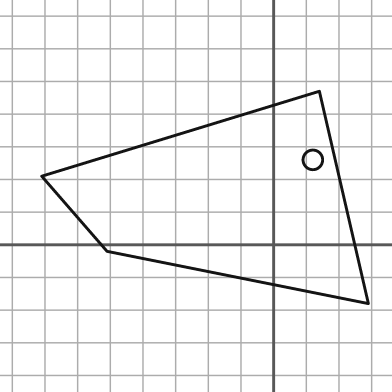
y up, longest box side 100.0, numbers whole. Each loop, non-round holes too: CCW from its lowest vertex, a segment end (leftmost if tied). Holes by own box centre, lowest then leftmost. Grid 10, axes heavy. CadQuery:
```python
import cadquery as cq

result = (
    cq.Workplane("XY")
    .moveTo(29.0, -18.0)
    .lineTo(14.0, 47.0)
    .lineTo(-71.0, 21.0)
    .lineTo(-51.0, -2.0)
    .close()
    .moveTo(12.0, 26.0)
    .circle(3.0)
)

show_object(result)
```